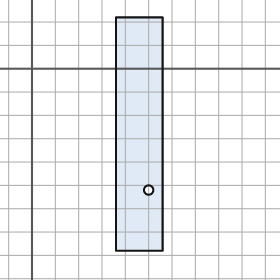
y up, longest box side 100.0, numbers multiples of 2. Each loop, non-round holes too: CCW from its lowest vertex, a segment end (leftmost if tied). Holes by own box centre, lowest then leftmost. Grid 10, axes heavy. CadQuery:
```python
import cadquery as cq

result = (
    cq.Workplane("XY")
    .moveTo(36.0, -78.0)
    .lineTo(56.0, -78.0)
    .lineTo(56.0, 22.0)
    .lineTo(36.0, 22.0)
    .close()
    .moveTo(50.0, -52.0)
    .circle(2.0)
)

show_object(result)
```